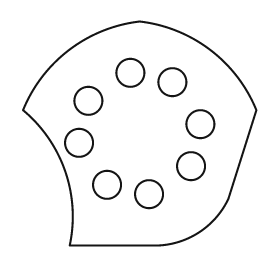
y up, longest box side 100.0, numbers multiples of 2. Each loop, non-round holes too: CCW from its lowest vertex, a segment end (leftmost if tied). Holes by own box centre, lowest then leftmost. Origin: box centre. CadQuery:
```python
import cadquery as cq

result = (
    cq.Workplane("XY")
    .moveTo(-30.0, -48.0)
    .lineTo(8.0, -48.0)
    .threePointArc((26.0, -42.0), (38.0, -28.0))
    .lineTo(50.0, 10.0)
    .threePointArc((30.0, 36.0), (0.0, 48.0))
    .threePointArc((-30.0, 36.0), (-50.0, 10.0))
    .threePointArc((-32.0, -16.0), (-30.0, -48.0))
    .close()
    .moveTo(4.0, -26.0)
    .circle(6.0)
    .moveTo(-14.0, -22.0)
    .circle(6.0)
    .moveTo(22.0, -14.0)
    .circle(6.0)
    .moveTo(-26.0, -4.0)
    .circle(6.0)
    .moveTo(26.0, 4.0)
    .circle(6.0)
    .moveTo(-22.0, 14.0)
    .circle(6.0)
    .moveTo(14.0, 22.0)
    .circle(6.0)
    .moveTo(-4.0, 26.0)
    .circle(6.0)
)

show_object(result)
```